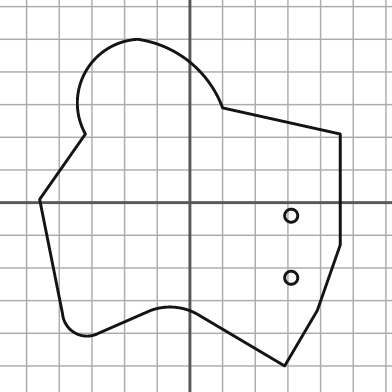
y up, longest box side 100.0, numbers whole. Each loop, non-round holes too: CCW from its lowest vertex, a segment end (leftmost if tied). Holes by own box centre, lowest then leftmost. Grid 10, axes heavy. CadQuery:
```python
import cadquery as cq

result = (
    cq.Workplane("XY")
    .moveTo(29.0, -50.0)
    .lineTo(39.0, -33.0)
    .lineTo(46.0, -13.0)
    .lineTo(46.0, 21.0)
    .lineTo(10.0, 29.0)
    .threePointArc((0.0, 43.0), (-16.0, 50.0))
    .threePointArc((-32.0, 40.0), (-32.0, 21.0))
    .lineTo(-46.0, 1.0)
    .lineTo(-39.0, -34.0)
    .threePointArc((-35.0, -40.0), (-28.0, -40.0))
    .lineTo(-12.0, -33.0)
    .threePointArc((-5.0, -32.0), (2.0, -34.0))
    .close()
    .moveTo(31.0, -23.0)
    .circle(2.0)
    .moveTo(31.0, -4.0)
    .circle(2.0)
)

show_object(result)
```